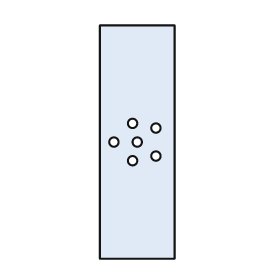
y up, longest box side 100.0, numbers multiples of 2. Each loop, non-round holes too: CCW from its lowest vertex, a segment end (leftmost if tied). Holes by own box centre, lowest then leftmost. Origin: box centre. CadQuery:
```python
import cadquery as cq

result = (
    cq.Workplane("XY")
    .moveTo(-16.0, -50.0)
    .lineTo(16.0, -50.0)
    .lineTo(16.0, 50.0)
    .lineTo(-16.0, 50.0)
    .close()
    .moveTo(-2.0, -8.0)
    .circle(2.0)
    .moveTo(8.0, -6.0)
    .circle(2.0)
    .moveTo(-10.0, 0.0)
    .circle(2.0)
    .moveTo(0.0, 0.0)
    .circle(2.0)
    .moveTo(8.0, 6.0)
    .circle(2.0)
    .moveTo(-2.0, 8.0)
    .circle(2.0)
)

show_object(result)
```